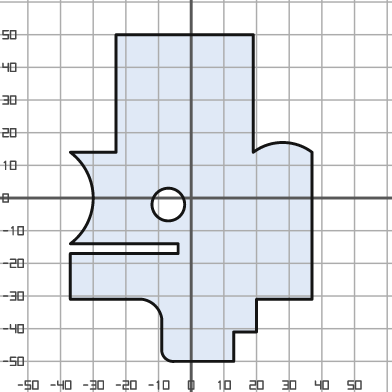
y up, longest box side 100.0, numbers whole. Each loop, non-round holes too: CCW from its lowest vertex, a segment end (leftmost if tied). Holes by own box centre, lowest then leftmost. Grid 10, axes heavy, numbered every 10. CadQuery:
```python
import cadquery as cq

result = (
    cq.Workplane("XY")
    .moveTo(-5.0, -50.0)
    .lineTo(13.0, -50.0)
    .lineTo(13.0, -41.0)
    .lineTo(20.0, -41.0)
    .lineTo(20.0, -31.0)
    .lineTo(37.0, -31.0)
    .lineTo(37.0, 14.0)
    .threePointArc((28.0, 17.0), (19.0, 14.0))
    .lineTo(19.0, 50.0)
    .lineTo(-23.0, 50.0)
    .lineTo(-23.0, 14.0)
    .lineTo(-37.0, 14.0)
    .threePointArc((-30.0, 0.0), (-37.0, -14.0))
    .lineTo(-4.0, -14.0)
    .lineTo(-4.0, -17.0)
    .lineTo(-37.0, -17.0)
    .lineTo(-37.0, -31.0)
    .lineTo(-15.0, -31.0)
    .threePointArc((-11.0, -33.0), (-9.0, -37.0))
    .lineTo(-9.0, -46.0)
    .threePointArc((-8.0, -49.0), (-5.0, -50.0))
    .close()
    .moveTo(-7.0, -2.0)
    .circle(5.0)
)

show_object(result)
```